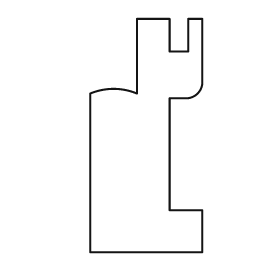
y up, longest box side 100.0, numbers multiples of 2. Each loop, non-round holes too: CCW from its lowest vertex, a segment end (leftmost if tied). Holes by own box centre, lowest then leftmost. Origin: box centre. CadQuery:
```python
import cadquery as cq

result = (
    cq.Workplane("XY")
    .moveTo(-24.0, -50.0)
    .lineTo(24.0, -50.0)
    .lineTo(24.0, -32.0)
    .lineTo(10.0, -32.0)
    .lineTo(10.0, 16.0)
    .lineTo(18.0, 16.0)
    .threePointArc((22.0, 18.0), (24.0, 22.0))
    .lineTo(24.0, 50.0)
    .lineTo(18.0, 50.0)
    .lineTo(18.0, 36.0)
    .lineTo(10.0, 36.0)
    .lineTo(10.0, 50.0)
    .lineTo(-4.0, 50.0)
    .lineTo(-4.0, 18.0)
    .threePointArc((-14.0, 20.0), (-24.0, 18.0))
    .close()
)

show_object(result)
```